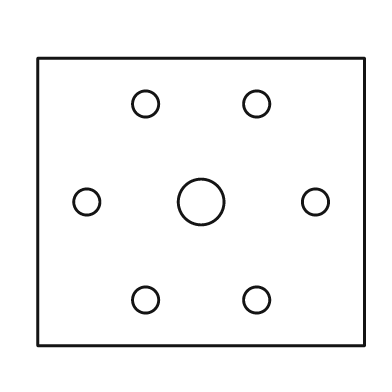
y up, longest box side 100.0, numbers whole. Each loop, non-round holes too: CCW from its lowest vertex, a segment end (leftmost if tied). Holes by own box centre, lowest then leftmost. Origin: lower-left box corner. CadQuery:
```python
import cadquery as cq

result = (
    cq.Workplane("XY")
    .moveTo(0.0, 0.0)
    .lineTo(100.0, 0.0)
    .lineTo(100.0, 88.0)
    .lineTo(0.0, 88.0)
    .close()
    .moveTo(33.0, 14.0)
    .circle(4.0)
    .moveTo(67.0, 14.0)
    .circle(4.0)
    .moveTo(15.0, 44.0)
    .circle(4.0)
    .moveTo(50.0, 44.0)
    .circle(7.0)
    .moveTo(85.0, 44.0)
    .circle(4.0)
    .moveTo(33.0, 74.0)
    .circle(4.0)
    .moveTo(67.0, 74.0)
    .circle(4.0)
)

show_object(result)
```